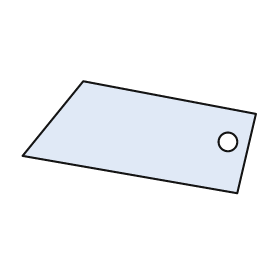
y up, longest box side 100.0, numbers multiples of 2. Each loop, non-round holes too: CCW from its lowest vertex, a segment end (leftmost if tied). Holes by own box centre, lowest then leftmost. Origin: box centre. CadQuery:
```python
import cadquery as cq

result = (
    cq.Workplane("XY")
    .moveTo(42.0, -24.0)
    .lineTo(50.0, 10.0)
    .lineTo(-24.0, 24.0)
    .lineTo(-50.0, -8.0)
    .close()
    .moveTo(38.0, -2.0)
    .circle(4.0)
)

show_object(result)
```